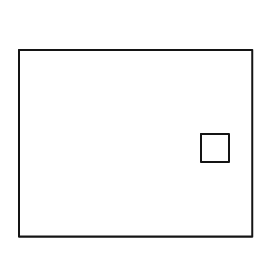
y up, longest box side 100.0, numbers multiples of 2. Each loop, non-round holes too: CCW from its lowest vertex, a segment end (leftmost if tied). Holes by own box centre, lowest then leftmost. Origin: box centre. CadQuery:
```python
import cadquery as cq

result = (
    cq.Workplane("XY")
    .moveTo(-50.0, -40.0)
    .lineTo(50.0, -40.0)
    .lineTo(50.0, 40.0)
    .lineTo(-50.0, 40.0)
    .close()
    .moveTo(28.0, -8.0)
    .lineTo(40.0, -8.0)
    .lineTo(40.0, 4.0)
    .lineTo(28.0, 4.0)
    .close()
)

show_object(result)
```